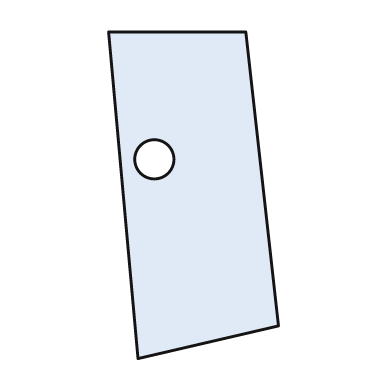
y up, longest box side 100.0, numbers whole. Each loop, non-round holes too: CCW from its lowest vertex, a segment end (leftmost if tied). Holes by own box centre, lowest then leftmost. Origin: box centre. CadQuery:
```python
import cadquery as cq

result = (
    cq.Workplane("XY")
    .moveTo(-17.0, -50.0)
    .lineTo(26.0, -40.0)
    .lineTo(16.0, 50.0)
    .lineTo(-26.0, 50.0)
    .close()
    .moveTo(-12.0, 11.0)
    .circle(6.0)
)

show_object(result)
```